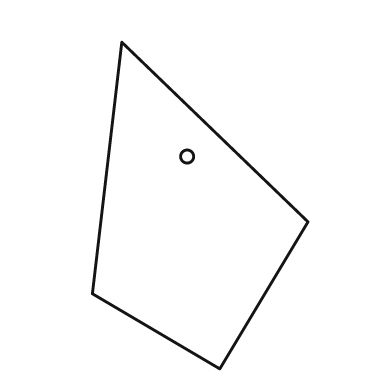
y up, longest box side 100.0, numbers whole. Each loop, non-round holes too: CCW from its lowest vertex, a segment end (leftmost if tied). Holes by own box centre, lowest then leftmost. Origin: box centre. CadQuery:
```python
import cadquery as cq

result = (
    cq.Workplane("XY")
    .moveTo(6.0, -50.0)
    .lineTo(33.0, -5.0)
    .lineTo(-24.0, 50.0)
    .lineTo(-33.0, -27.0)
    .close()
    .moveTo(-4.0, 15.0)
    .circle(2.0)
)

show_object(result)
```